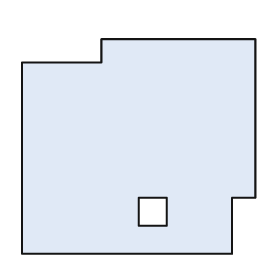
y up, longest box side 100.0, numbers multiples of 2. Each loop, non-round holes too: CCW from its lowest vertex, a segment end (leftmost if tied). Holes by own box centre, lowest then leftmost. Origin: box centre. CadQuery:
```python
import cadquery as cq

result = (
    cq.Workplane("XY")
    .moveTo(-50.0, -46.0)
    .lineTo(40.0, -46.0)
    .lineTo(40.0, -22.0)
    .lineTo(50.0, -22.0)
    .lineTo(50.0, 46.0)
    .lineTo(-16.0, 46.0)
    .lineTo(-16.0, 36.0)
    .lineTo(-50.0, 36.0)
    .close()
    .moveTo(0.0, -34.0)
    .lineTo(12.0, -34.0)
    .lineTo(12.0, -22.0)
    .lineTo(0.0, -22.0)
    .close()
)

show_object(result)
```